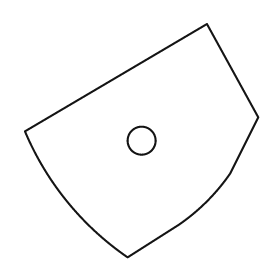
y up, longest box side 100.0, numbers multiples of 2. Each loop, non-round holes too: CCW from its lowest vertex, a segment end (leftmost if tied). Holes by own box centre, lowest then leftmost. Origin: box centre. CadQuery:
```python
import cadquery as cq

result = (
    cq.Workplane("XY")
    .moveTo(-6.0, -50.0)
    .lineTo(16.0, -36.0)
    .threePointArc((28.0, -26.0), (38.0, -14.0))
    .lineTo(50.0, 10.0)
    .lineTo(28.0, 50.0)
    .lineTo(-50.0, 4.0)
    .threePointArc((-32.0, -26.0), (-6.0, -50.0))
    .close()
    .moveTo(0.0, 0.0)
    .circle(6.0)
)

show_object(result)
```